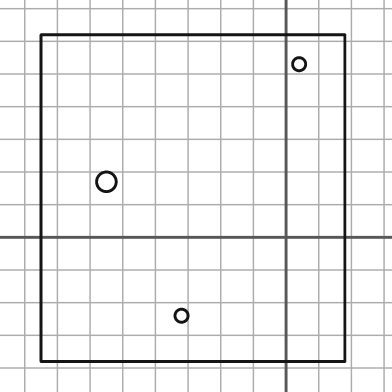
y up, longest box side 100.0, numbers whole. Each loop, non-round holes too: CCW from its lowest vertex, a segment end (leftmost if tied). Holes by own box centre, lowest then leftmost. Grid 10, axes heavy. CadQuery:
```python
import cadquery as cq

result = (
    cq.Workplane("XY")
    .moveTo(-75.0, -38.0)
    .lineTo(18.0, -38.0)
    .lineTo(18.0, 62.0)
    .lineTo(-75.0, 62.0)
    .close()
    .moveTo(-32.0, -24.0)
    .circle(2.0)
    .moveTo(-55.0, 17.0)
    .circle(3.0)
    .moveTo(4.0, 53.0)
    .circle(2.0)
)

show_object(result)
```